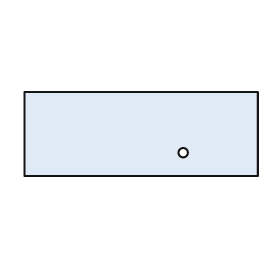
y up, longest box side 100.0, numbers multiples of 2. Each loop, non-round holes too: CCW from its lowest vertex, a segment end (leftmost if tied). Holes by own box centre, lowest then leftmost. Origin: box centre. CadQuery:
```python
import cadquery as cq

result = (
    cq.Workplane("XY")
    .moveTo(-50.0, -18.0)
    .lineTo(50.0, -18.0)
    .lineTo(50.0, 18.0)
    .lineTo(-50.0, 18.0)
    .close()
    .moveTo(18.0, -8.0)
    .circle(2.0)
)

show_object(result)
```